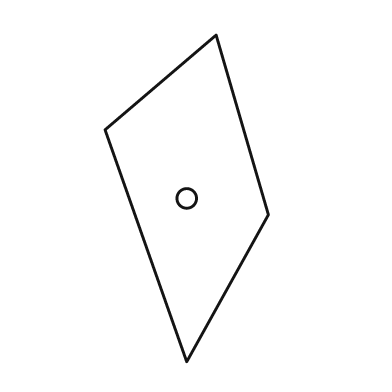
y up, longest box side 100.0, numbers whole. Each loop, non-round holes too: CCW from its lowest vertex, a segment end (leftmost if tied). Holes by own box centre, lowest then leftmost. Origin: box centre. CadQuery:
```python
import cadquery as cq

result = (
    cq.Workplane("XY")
    .moveTo(0.0, -50.0)
    .lineTo(25.0, -5.0)
    .lineTo(9.0, 50.0)
    .lineTo(-25.0, 21.0)
    .close()
    .moveTo(0.0, 0.0)
    .circle(3.0)
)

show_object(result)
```